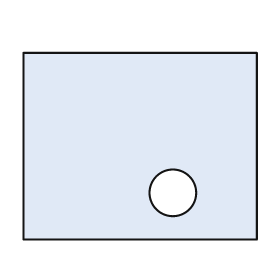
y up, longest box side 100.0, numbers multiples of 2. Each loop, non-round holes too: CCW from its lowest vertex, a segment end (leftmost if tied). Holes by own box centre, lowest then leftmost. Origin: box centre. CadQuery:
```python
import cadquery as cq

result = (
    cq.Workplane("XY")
    .moveTo(-50.0, -40.0)
    .lineTo(50.0, -40.0)
    .lineTo(50.0, 40.0)
    .lineTo(-50.0, 40.0)
    .close()
    .moveTo(14.0, -20.0)
    .circle(10.0)
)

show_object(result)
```